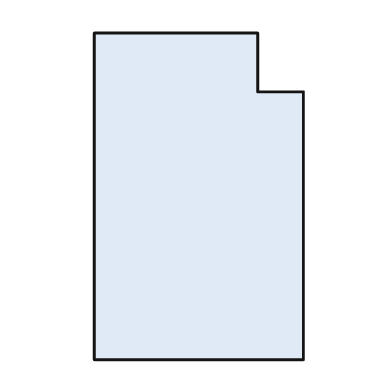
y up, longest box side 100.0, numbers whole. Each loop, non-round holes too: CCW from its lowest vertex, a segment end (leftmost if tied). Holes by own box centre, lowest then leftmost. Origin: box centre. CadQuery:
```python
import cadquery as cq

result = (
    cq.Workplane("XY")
    .moveTo(-32.0, -50.0)
    .lineTo(32.0, -50.0)
    .lineTo(32.0, 32.0)
    .lineTo(18.0, 32.0)
    .lineTo(18.0, 50.0)
    .lineTo(-32.0, 50.0)
    .close()
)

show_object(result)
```